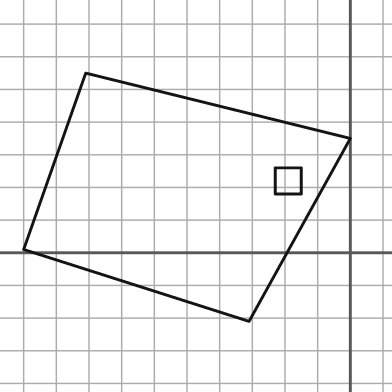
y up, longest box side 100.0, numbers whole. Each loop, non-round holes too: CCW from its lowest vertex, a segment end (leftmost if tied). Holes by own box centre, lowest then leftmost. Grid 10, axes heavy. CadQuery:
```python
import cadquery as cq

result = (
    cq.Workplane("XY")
    .moveTo(-31.0, -21.0)
    .lineTo(0.0, 35.0)
    .lineTo(-81.0, 55.0)
    .lineTo(-100.0, 1.0)
    .close()
    .moveTo(-23.0, 18.0)
    .lineTo(-15.0, 18.0)
    .lineTo(-15.0, 26.0)
    .lineTo(-23.0, 26.0)
    .close()
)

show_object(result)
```